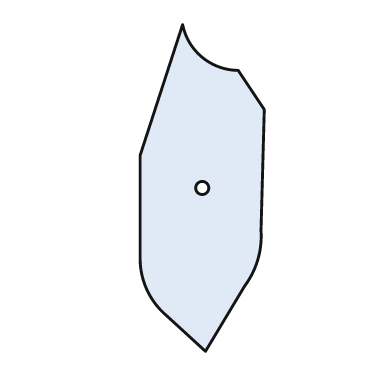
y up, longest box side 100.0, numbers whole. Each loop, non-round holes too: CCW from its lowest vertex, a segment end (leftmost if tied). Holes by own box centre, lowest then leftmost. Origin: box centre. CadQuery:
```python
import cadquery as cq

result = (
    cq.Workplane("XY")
    .moveTo(1.0, -50.0)
    .lineTo(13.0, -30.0)
    .threePointArc((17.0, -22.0), (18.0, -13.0))
    .lineTo(19.0, 24.0)
    .lineTo(11.0, 36.0)
    .threePointArc((0.0, 40.0), (-6.0, 50.0))
    .lineTo(-19.0, 10.0)
    .lineTo(-19.0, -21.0)
    .threePointArc((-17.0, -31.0), (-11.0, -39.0))
    .close()
    .moveTo(0.0, 0.0)
    .circle(2.0)
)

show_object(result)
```